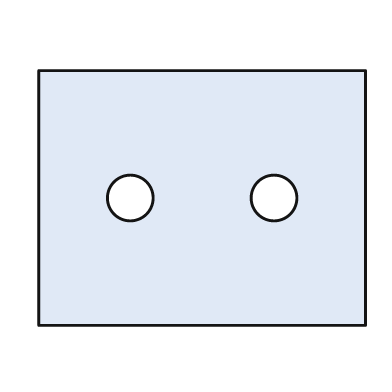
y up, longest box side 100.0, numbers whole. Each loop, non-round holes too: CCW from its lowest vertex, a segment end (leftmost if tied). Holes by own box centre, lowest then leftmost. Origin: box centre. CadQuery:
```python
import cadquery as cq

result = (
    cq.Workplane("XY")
    .moveTo(-50.0, -39.0)
    .lineTo(50.0, -39.0)
    .lineTo(50.0, 39.0)
    .lineTo(-50.0, 39.0)
    .close()
    .moveTo(-22.0, 0.0)
    .circle(7.0)
    .moveTo(22.0, 0.0)
    .circle(7.0)
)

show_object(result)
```